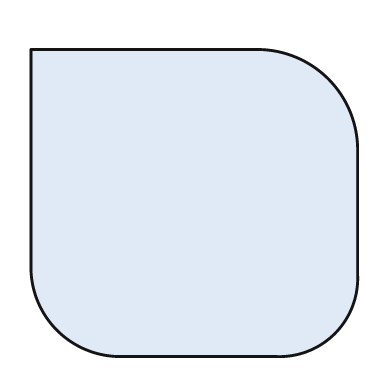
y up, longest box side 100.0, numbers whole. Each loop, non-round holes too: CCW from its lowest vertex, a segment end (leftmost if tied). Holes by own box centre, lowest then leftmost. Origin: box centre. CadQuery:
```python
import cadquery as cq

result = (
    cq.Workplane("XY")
    .moveTo(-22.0, -47.0)
    .lineTo(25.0, -47.0)
    .threePointArc((43.0, -40.0), (50.0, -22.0))
    .lineTo(50.0, 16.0)
    .threePointArc((41.0, 38.0), (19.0, 47.0))
    .lineTo(-50.0, 47.0)
    .lineTo(-50.0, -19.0)
    .threePointArc((-42.0, -39.0), (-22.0, -47.0))
    .close()
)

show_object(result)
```